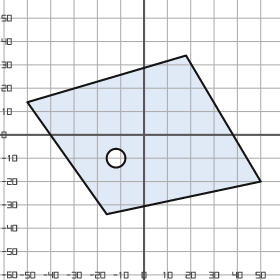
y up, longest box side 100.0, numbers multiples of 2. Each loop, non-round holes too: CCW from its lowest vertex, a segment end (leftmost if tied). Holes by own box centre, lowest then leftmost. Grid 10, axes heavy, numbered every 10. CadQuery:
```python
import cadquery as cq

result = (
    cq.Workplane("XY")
    .moveTo(-16.0, -34.0)
    .lineTo(50.0, -20.0)
    .lineTo(18.0, 34.0)
    .lineTo(-50.0, 14.0)
    .close()
    .moveTo(-12.0, -10.0)
    .circle(4.0)
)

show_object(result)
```